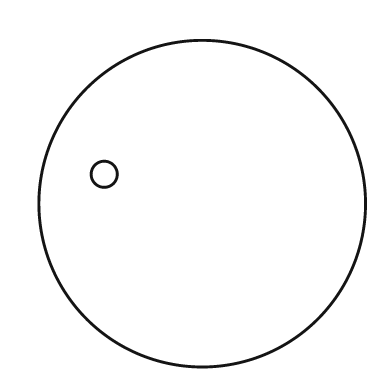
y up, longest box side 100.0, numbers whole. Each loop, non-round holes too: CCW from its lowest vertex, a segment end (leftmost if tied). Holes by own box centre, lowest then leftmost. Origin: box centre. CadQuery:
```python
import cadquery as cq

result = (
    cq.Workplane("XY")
    .moveTo(0.0, 0.0)
    .circle(50.0)
    .moveTo(-30.0, 9.0)
    .circle(4.0)
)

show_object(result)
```